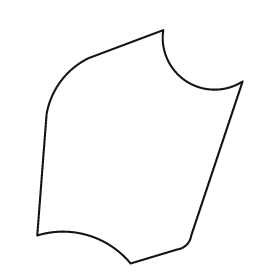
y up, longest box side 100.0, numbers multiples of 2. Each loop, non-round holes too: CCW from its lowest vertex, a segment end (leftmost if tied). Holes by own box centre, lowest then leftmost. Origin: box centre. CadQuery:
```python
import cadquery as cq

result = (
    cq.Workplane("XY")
    .moveTo(-4.0, -50.0)
    .lineTo(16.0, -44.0)
    .threePointArc((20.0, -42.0), (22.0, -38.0))
    .lineTo(44.0, 28.0)
    .threePointArc((20.0, 28.0), (10.0, 50.0))
    .lineTo(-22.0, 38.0)
    .threePointArc((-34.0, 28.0), (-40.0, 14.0))
    .lineTo(-44.0, -38.0)
    .threePointArc((-22.0, -38.0), (-4.0, -50.0))
    .close()
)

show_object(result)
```